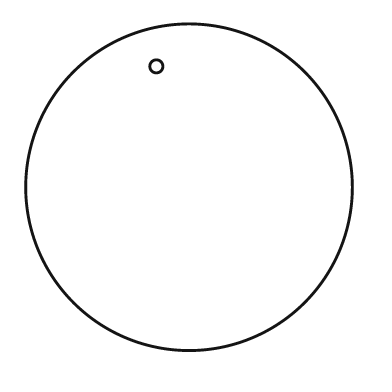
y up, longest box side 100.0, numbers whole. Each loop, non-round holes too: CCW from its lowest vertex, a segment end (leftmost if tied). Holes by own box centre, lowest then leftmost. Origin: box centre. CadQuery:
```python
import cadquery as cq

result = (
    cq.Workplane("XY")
    .moveTo(0.0, 0.0)
    .circle(50.0)
    .moveTo(-10.0, 37.0)
    .circle(2.0)
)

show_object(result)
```